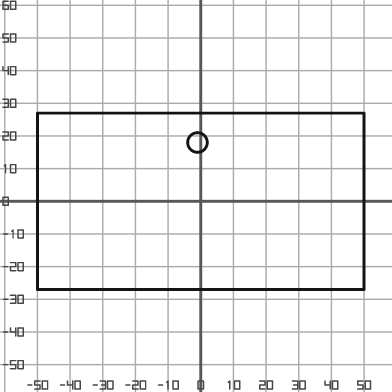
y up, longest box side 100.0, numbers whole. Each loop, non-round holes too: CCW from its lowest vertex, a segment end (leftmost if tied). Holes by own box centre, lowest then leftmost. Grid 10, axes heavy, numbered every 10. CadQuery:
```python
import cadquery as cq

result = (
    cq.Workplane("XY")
    .moveTo(-50.0, -27.0)
    .lineTo(50.0, -27.0)
    .lineTo(50.0, 27.0)
    .lineTo(-50.0, 27.0)
    .close()
    .moveTo(-1.0, 18.0)
    .circle(3.0)
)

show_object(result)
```